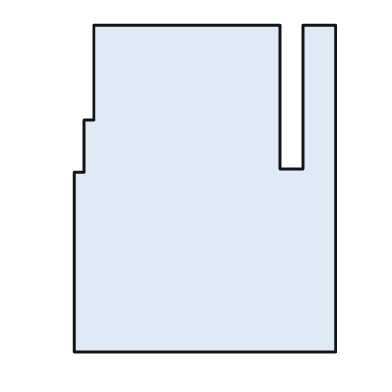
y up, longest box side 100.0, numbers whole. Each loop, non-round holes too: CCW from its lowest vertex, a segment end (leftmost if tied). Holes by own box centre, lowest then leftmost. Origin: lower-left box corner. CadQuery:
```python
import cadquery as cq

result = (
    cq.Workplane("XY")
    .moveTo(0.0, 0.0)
    .lineTo(80.0, 0.0)
    .lineTo(80.0, 100.0)
    .lineTo(70.0, 100.0)
    .lineTo(70.0, 56.0)
    .lineTo(63.0, 56.0)
    .lineTo(63.0, 100.0)
    .lineTo(6.0, 100.0)
    .lineTo(6.0, 71.0)
    .lineTo(3.0, 71.0)
    .lineTo(3.0, 55.0)
    .lineTo(0.0, 55.0)
    .close()
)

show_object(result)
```